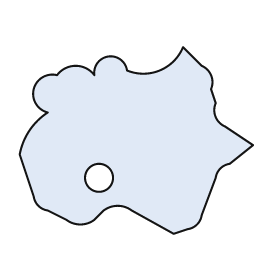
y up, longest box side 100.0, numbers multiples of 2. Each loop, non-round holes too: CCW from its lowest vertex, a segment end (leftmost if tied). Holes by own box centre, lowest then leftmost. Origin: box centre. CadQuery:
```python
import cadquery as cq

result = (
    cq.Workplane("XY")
    .moveTo(16.0, -40.0)
    .lineTo(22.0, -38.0)
    .threePointArc((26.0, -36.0), (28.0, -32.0))
    .lineTo(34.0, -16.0)
    .threePointArc((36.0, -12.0), (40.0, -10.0))
    .lineTo(50.0, -2.0)
    .lineTo(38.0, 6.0)
    .threePointArc((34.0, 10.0), (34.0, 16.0))
    .lineTo(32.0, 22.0)
    .threePointArc((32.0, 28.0), (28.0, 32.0))
    .lineTo(20.0, 40.0)
    .threePointArc((10.0, 30.0), (-4.0, 30.0))
    .threePointArc((-12.0, 36.0), (-18.0, 28.0))
    .threePointArc((-26.0, 32.0), (-34.0, 28.0))
    .threePointArc((-44.0, 22.0), (-38.0, 12.0))
    .threePointArc((-46.0, 4.0), (-50.0, -6.0))
    .lineTo(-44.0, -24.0)
    .threePointArc((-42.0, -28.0), (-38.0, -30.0))
    .lineTo(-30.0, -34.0)
    .threePointArc((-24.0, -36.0), (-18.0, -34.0))
    .lineTo(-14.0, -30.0)
    .threePointArc((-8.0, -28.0), (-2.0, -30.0))
    .close()
    .moveTo(-16.0, -16.0)
    .circle(6.0)
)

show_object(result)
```